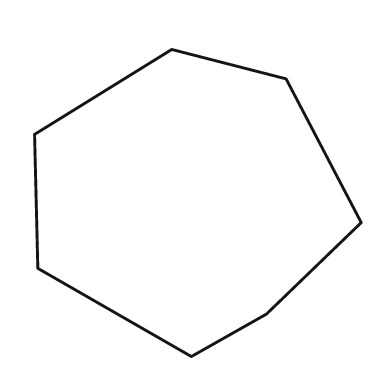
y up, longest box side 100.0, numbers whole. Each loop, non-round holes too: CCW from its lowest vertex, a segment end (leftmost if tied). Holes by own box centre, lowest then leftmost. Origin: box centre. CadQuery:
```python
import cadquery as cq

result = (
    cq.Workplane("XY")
    .moveTo(-2.0, -47.0)
    .lineTo(21.0, -34.0)
    .lineTo(50.0, -6.0)
    .lineTo(27.0, 38.0)
    .lineTo(-8.0, 47.0)
    .lineTo(-50.0, 21.0)
    .lineTo(-49.0, -20.0)
    .close()
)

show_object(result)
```